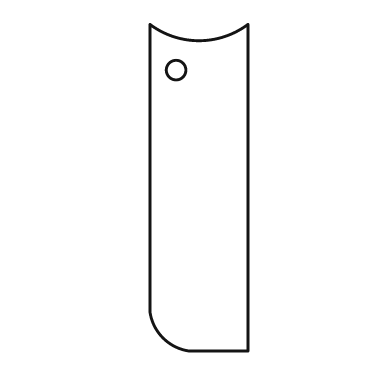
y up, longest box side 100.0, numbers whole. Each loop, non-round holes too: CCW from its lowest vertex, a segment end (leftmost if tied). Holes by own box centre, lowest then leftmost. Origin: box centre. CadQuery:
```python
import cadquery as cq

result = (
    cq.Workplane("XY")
    .moveTo(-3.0, -50.0)
    .lineTo(15.0, -50.0)
    .lineTo(15.0, 50.0)
    .threePointArc((0.0, 45.0), (-15.0, 50.0))
    .lineTo(-15.0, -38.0)
    .threePointArc((-11.0, -46.0), (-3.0, -50.0))
    .close()
    .moveTo(-7.0, 36.0)
    .circle(3.0)
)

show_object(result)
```